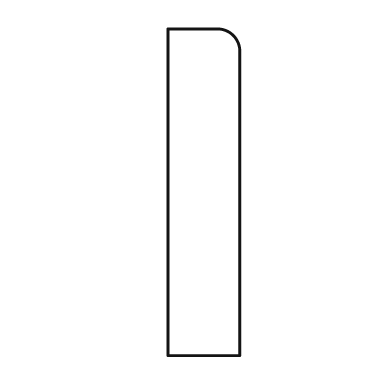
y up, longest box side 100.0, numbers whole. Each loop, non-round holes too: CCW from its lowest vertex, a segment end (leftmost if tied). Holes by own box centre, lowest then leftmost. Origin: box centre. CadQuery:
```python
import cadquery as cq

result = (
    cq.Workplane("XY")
    .moveTo(-11.0, -50.0)
    .lineTo(11.0, -50.0)
    .lineTo(11.0, 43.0)
    .threePointArc((9.0, 48.0), (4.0, 50.0))
    .lineTo(-11.0, 50.0)
    .close()
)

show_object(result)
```